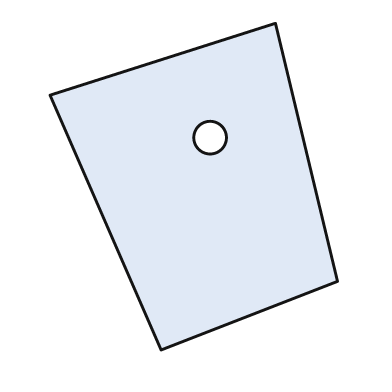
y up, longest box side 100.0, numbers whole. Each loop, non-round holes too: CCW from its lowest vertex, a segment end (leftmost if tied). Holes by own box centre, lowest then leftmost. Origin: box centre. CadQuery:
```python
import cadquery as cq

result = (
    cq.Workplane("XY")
    .moveTo(-10.0, -50.0)
    .lineTo(44.0, -29.0)
    .lineTo(25.0, 50.0)
    .lineTo(-44.0, 28.0)
    .close()
    .moveTo(5.0, 15.0)
    .circle(5.0)
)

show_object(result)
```